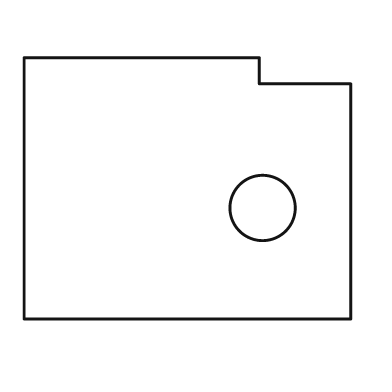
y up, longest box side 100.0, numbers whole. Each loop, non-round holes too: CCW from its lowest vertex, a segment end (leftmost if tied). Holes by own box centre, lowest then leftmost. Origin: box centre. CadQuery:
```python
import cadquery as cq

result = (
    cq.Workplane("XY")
    .moveTo(-50.0, -40.0)
    .lineTo(50.0, -40.0)
    .lineTo(50.0, 32.0)
    .lineTo(22.0, 32.0)
    .lineTo(22.0, 40.0)
    .lineTo(-50.0, 40.0)
    .close()
    .moveTo(23.0, -6.0)
    .circle(10.0)
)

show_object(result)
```